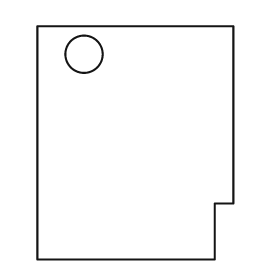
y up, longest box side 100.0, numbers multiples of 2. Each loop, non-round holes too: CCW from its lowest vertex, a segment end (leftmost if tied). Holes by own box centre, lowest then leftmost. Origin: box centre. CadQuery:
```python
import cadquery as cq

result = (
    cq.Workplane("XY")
    .moveTo(-42.0, -50.0)
    .lineTo(34.0, -50.0)
    .lineTo(34.0, -26.0)
    .lineTo(42.0, -26.0)
    .lineTo(42.0, 50.0)
    .lineTo(-42.0, 50.0)
    .close()
    .moveTo(-22.0, 38.0)
    .circle(8.0)
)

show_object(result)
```